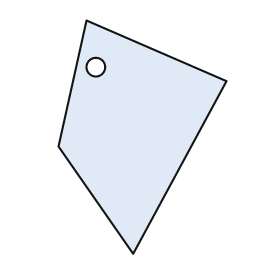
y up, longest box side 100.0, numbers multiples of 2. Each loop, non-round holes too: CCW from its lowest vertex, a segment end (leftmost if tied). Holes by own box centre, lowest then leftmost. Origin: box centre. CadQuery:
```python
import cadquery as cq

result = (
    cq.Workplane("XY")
    .moveTo(-4.0, -50.0)
    .lineTo(36.0, 24.0)
    .lineTo(-24.0, 50.0)
    .lineTo(-36.0, -4.0)
    .close()
    .moveTo(-20.0, 30.0)
    .circle(4.0)
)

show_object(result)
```